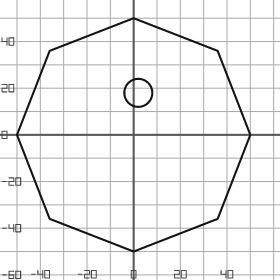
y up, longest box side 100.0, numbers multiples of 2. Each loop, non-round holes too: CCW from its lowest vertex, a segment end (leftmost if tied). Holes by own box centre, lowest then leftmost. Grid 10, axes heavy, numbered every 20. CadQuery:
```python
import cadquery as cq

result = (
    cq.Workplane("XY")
    .moveTo(0.0, -50.0)
    .lineTo(36.0, -36.0)
    .lineTo(50.0, 0.0)
    .lineTo(36.0, 36.0)
    .lineTo(0.0, 50.0)
    .lineTo(-36.0, 36.0)
    .lineTo(-50.0, 0.0)
    .lineTo(-36.0, -36.0)
    .close()
    .moveTo(2.0, 18.0)
    .circle(6.0)
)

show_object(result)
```